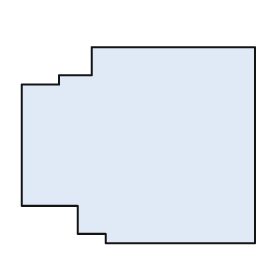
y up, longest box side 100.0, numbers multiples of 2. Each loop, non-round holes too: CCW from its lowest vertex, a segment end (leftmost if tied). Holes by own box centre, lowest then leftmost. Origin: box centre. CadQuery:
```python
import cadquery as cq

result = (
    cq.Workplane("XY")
    .moveTo(-14.0, -42.0)
    .lineTo(50.0, -42.0)
    .lineTo(50.0, 42.0)
    .lineTo(-20.0, 42.0)
    .lineTo(-20.0, 30.0)
    .lineTo(-34.0, 30.0)
    .lineTo(-34.0, 26.0)
    .lineTo(-50.0, 26.0)
    .lineTo(-50.0, -26.0)
    .lineTo(-26.0, -26.0)
    .lineTo(-26.0, -38.0)
    .lineTo(-14.0, -38.0)
    .close()
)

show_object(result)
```